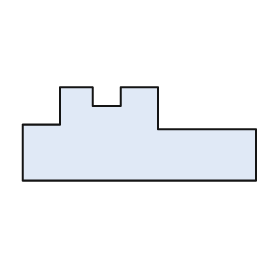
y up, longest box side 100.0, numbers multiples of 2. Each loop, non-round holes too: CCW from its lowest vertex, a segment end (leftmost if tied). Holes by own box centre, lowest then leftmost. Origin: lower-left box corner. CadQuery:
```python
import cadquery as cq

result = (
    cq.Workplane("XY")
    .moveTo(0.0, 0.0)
    .lineTo(100.0, 0.0)
    .lineTo(100.0, 22.0)
    .lineTo(58.0, 22.0)
    .lineTo(58.0, 40.0)
    .lineTo(42.0, 40.0)
    .lineTo(42.0, 32.0)
    .lineTo(30.0, 32.0)
    .lineTo(30.0, 40.0)
    .lineTo(16.0, 40.0)
    .lineTo(16.0, 24.0)
    .lineTo(0.0, 24.0)
    .close()
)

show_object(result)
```